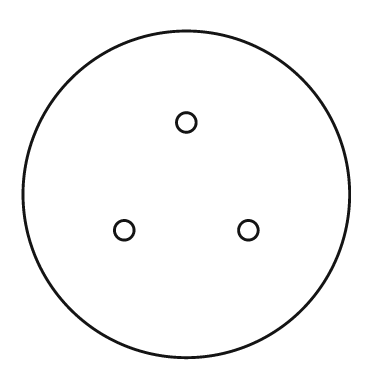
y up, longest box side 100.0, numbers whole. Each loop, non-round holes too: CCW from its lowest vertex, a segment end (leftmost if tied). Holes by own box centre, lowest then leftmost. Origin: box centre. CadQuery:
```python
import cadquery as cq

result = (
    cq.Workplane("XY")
    .moveTo(0.0, 0.0)
    .circle(50.0)
    .moveTo(-19.0, -11.0)
    .circle(3.0)
    .moveTo(19.0, -11.0)
    .circle(3.0)
    .moveTo(0.0, 22.0)
    .circle(3.0)
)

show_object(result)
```